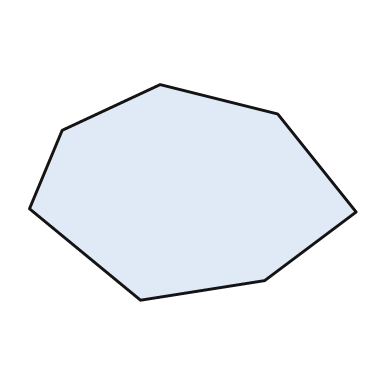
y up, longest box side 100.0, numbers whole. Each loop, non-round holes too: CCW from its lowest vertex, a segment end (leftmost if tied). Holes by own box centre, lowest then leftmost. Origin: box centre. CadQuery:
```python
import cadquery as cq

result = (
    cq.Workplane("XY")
    .moveTo(-16.0, -33.0)
    .lineTo(22.0, -27.0)
    .lineTo(50.0, -6.0)
    .lineTo(26.0, 24.0)
    .lineTo(-10.0, 33.0)
    .lineTo(-40.0, 19.0)
    .lineTo(-50.0, -5.0)
    .close()
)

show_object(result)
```